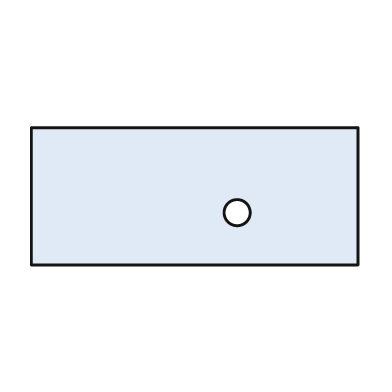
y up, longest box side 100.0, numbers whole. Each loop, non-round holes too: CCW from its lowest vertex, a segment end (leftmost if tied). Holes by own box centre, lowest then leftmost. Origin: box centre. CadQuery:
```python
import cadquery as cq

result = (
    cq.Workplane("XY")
    .moveTo(-50.0, -21.0)
    .lineTo(50.0, -21.0)
    .lineTo(50.0, 21.0)
    .lineTo(-50.0, 21.0)
    .close()
    .moveTo(13.0, -5.0)
    .circle(4.0)
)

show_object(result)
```